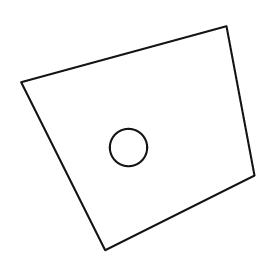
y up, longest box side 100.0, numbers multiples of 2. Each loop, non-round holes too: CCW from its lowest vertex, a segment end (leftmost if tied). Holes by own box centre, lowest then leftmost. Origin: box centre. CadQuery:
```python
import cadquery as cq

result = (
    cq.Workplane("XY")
    .moveTo(-14.0, -48.0)
    .lineTo(50.0, -16.0)
    .lineTo(38.0, 48.0)
    .lineTo(-50.0, 24.0)
    .close()
    .moveTo(-4.0, -4.0)
    .circle(8.0)
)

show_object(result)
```